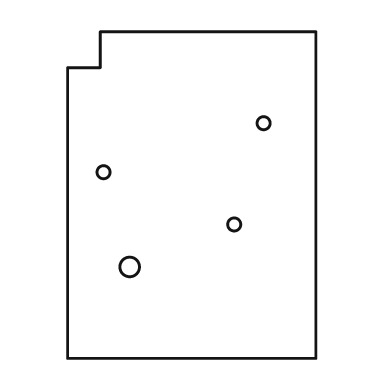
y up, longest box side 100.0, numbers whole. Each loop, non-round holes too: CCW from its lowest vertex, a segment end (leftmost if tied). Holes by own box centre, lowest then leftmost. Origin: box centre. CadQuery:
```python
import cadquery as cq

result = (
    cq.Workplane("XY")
    .moveTo(-38.0, -50.0)
    .lineTo(38.0, -50.0)
    .lineTo(38.0, 50.0)
    .lineTo(-28.0, 50.0)
    .lineTo(-28.0, 39.0)
    .lineTo(-38.0, 39.0)
    .close()
    .moveTo(-19.0, -22.0)
    .circle(3.0)
    .moveTo(13.0, -9.0)
    .circle(2.0)
    .moveTo(-27.0, 7.0)
    .circle(2.0)
    .moveTo(22.0, 22.0)
    .circle(2.0)
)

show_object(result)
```